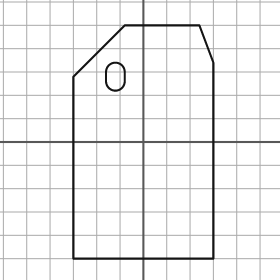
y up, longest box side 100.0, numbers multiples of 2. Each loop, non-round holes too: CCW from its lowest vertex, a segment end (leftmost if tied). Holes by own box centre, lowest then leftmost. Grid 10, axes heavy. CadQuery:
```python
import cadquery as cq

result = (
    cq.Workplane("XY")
    .moveTo(-30.0, -50.0)
    .lineTo(30.0, -50.0)
    .lineTo(30.0, 34.0)
    .lineTo(24.0, 50.0)
    .lineTo(-8.0, 50.0)
    .lineTo(-30.0, 28.0)
    .close()
    .moveTo(-16.0, 26.0)
    .threePointArc((-12.0, 22.0), (-8.0, 26.0))
    .lineTo(-8.0, 30.0)
    .threePointArc((-12.0, 34.0), (-16.0, 30.0))
    .close()
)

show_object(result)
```